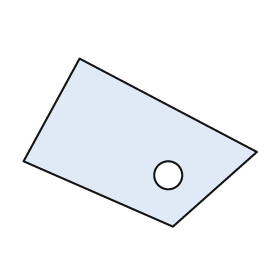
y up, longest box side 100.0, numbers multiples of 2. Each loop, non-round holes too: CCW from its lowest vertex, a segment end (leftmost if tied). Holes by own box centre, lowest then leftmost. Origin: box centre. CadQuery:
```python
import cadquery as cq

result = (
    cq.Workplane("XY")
    .moveTo(14.0, -36.0)
    .lineTo(50.0, -4.0)
    .lineTo(-26.0, 36.0)
    .lineTo(-50.0, -8.0)
    .close()
    .moveTo(12.0, -14.0)
    .circle(6.0)
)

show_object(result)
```